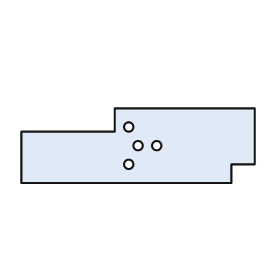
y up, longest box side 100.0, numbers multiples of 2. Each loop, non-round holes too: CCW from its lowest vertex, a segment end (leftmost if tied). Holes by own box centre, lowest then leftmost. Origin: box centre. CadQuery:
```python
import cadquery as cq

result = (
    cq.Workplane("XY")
    .moveTo(-50.0, -16.0)
    .lineTo(40.0, -16.0)
    .lineTo(40.0, -8.0)
    .lineTo(50.0, -8.0)
    .lineTo(50.0, 16.0)
    .lineTo(-10.0, 16.0)
    .lineTo(-10.0, 6.0)
    .lineTo(-50.0, 6.0)
    .close()
    .moveTo(-4.0, -8.0)
    .circle(2.0)
    .moveTo(0.0, 0.0)
    .circle(2.0)
    .moveTo(8.0, 0.0)
    .circle(2.0)
    .moveTo(-4.0, 8.0)
    .circle(2.0)
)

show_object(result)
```